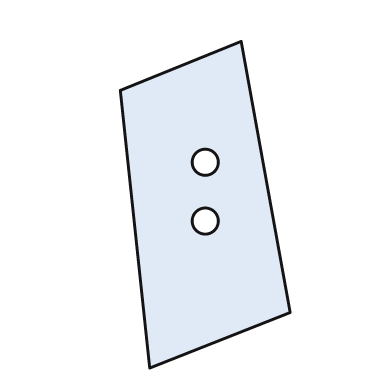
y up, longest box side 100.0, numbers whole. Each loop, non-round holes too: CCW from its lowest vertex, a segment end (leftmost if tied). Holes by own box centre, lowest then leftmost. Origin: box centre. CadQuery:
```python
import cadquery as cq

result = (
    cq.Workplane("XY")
    .moveTo(-17.0, -50.0)
    .lineTo(26.0, -33.0)
    .lineTo(11.0, 50.0)
    .lineTo(-26.0, 35.0)
    .close()
    .moveTo(0.0, -5.0)
    .circle(4.0)
    .moveTo(0.0, 13.0)
    .circle(4.0)
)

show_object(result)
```